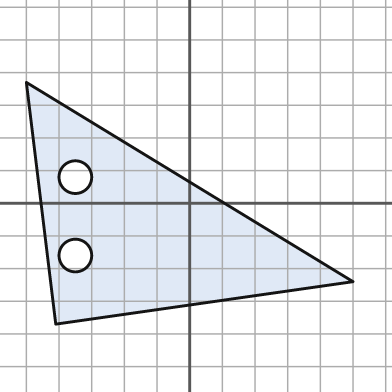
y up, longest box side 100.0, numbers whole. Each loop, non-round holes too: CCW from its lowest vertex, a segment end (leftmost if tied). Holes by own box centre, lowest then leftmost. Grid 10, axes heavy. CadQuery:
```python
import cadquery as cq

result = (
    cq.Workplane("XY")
    .moveTo(-41.0, -37.0)
    .lineTo(50.0, -24.0)
    .lineTo(-50.0, 37.0)
    .close()
    .moveTo(-35.0, -16.0)
    .circle(5.0)
    .moveTo(-35.0, 8.0)
    .circle(5.0)
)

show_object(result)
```